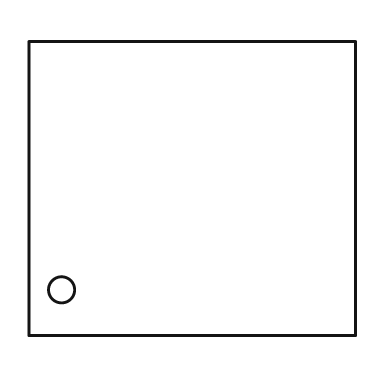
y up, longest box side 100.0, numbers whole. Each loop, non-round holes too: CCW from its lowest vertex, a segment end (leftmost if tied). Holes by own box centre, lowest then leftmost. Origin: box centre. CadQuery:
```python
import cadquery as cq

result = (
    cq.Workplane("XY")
    .moveTo(-50.0, -45.0)
    .lineTo(50.0, -45.0)
    .lineTo(50.0, 45.0)
    .lineTo(-50.0, 45.0)
    .close()
    .moveTo(-40.0, -31.0)
    .circle(4.0)
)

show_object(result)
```